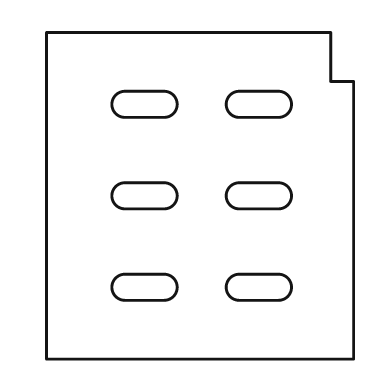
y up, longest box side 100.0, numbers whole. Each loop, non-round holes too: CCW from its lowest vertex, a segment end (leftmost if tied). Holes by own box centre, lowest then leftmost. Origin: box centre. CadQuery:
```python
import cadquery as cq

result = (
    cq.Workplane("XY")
    .moveTo(-47.0, -50.0)
    .lineTo(47.0, -50.0)
    .lineTo(47.0, 35.0)
    .lineTo(40.0, 35.0)
    .lineTo(40.0, 50.0)
    .lineTo(-47.0, 50.0)
    .close()
    .moveTo(-23.0, -32.0)
    .lineTo(-11.0, -32.0)
    .threePointArc((-7.0, -28.0), (-11.0, -24.0))
    .lineTo(-23.0, -24.0)
    .threePointArc((-27.0, -28.0), (-23.0, -32.0))
    .close()
    .moveTo(12.0, -32.0)
    .lineTo(24.0, -32.0)
    .threePointArc((28.0, -28.0), (24.0, -24.0))
    .lineTo(12.0, -24.0)
    .threePointArc((8.0, -28.0), (12.0, -32.0))
    .close()
    .moveTo(-23.0, -4.0)
    .lineTo(-11.0, -4.0)
    .threePointArc((-7.0, 0.0), (-11.0, 4.0))
    .lineTo(-23.0, 4.0)
    .threePointArc((-27.0, 0.0), (-23.0, -4.0))
    .close()
    .moveTo(12.0, -4.0)
    .lineTo(24.0, -4.0)
    .threePointArc((28.0, 0.0), (24.0, 4.0))
    .lineTo(12.0, 4.0)
    .threePointArc((8.0, 0.0), (12.0, -4.0))
    .close()
    .moveTo(-23.0, 24.0)
    .lineTo(-11.0, 24.0)
    .threePointArc((-7.0, 28.0), (-11.0, 32.0))
    .lineTo(-23.0, 32.0)
    .threePointArc((-27.0, 28.0), (-23.0, 24.0))
    .close()
    .moveTo(12.0, 24.0)
    .lineTo(24.0, 24.0)
    .threePointArc((28.0, 28.0), (24.0, 32.0))
    .lineTo(12.0, 32.0)
    .threePointArc((8.0, 28.0), (12.0, 24.0))
    .close()
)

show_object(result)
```